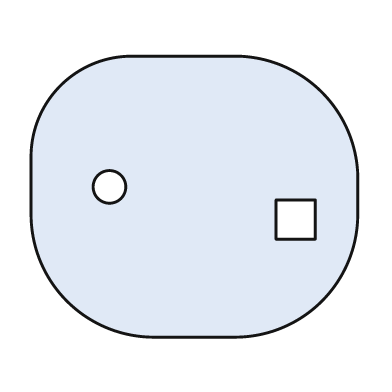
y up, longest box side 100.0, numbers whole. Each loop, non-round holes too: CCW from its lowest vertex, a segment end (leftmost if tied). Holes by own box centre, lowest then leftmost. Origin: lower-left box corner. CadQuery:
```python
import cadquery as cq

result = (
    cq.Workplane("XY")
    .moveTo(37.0, 0.0)
    .lineTo(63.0, 0.0)
    .threePointArc((89.0, 11.0), (100.0, 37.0))
    .lineTo(100.0, 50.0)
    .threePointArc((89.0, 75.0), (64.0, 86.0))
    .lineTo(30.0, 86.0)
    .threePointArc((9.0, 77.0), (0.0, 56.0))
    .lineTo(0.0, 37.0)
    .threePointArc((11.0, 11.0), (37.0, 0.0))
    .close()
    .moveTo(75.0, 30.0)
    .lineTo(87.0, 30.0)
    .lineTo(87.0, 42.0)
    .lineTo(75.0, 42.0)
    .close()
    .moveTo(24.0, 46.0)
    .circle(5.0)
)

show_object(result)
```